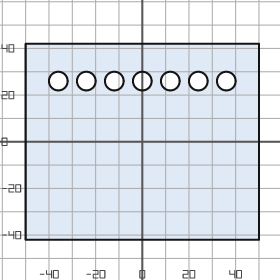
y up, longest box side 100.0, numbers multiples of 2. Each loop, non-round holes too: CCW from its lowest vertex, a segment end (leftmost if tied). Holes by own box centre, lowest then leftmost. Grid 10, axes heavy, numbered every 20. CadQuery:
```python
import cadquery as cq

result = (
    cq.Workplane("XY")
    .moveTo(-50.0, -42.0)
    .lineTo(50.0, -42.0)
    .lineTo(50.0, 42.0)
    .lineTo(-50.0, 42.0)
    .close()
    .moveTo(-36.0, 26.0)
    .circle(4.0)
    .moveTo(-24.0, 26.0)
    .circle(4.0)
    .moveTo(-12.0, 26.0)
    .circle(4.0)
    .moveTo(0.0, 26.0)
    .circle(4.0)
    .moveTo(12.0, 26.0)
    .circle(4.0)
    .moveTo(24.0, 26.0)
    .circle(4.0)
    .moveTo(36.0, 26.0)
    .circle(4.0)
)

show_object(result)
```